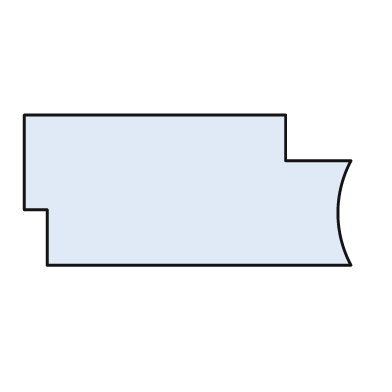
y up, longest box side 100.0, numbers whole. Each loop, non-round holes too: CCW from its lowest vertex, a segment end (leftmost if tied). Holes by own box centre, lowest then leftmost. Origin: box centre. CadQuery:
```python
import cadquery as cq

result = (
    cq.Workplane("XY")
    .moveTo(-43.0, -23.0)
    .lineTo(50.0, -23.0)
    .threePointArc((46.0, -7.0), (50.0, 9.0))
    .lineTo(30.0, 9.0)
    .lineTo(30.0, 23.0)
    .lineTo(-50.0, 23.0)
    .lineTo(-50.0, -6.0)
    .lineTo(-43.0, -6.0)
    .close()
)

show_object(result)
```